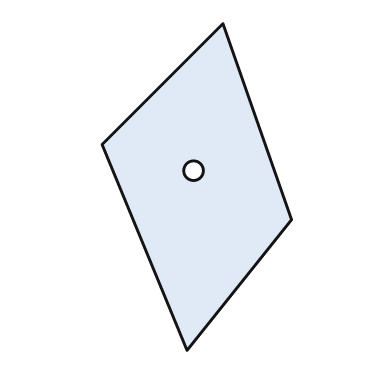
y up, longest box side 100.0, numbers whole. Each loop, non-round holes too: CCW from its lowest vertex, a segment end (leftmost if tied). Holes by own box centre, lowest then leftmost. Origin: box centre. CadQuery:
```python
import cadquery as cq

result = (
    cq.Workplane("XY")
    .moveTo(-3.0, -50.0)
    .lineTo(29.0, -10.0)
    .lineTo(8.0, 50.0)
    .lineTo(-29.0, 13.0)
    .close()
    .moveTo(-1.0, 5.0)
    .circle(3.0)
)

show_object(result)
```